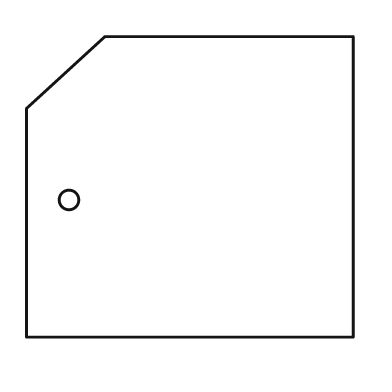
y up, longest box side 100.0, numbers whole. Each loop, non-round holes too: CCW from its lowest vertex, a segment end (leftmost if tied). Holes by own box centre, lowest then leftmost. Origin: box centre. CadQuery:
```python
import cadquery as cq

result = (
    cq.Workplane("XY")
    .moveTo(-50.0, -46.0)
    .lineTo(50.0, -46.0)
    .lineTo(50.0, 46.0)
    .lineTo(-26.0, 46.0)
    .lineTo(-50.0, 24.0)
    .close()
    .moveTo(-37.0, -4.0)
    .circle(3.0)
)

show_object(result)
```